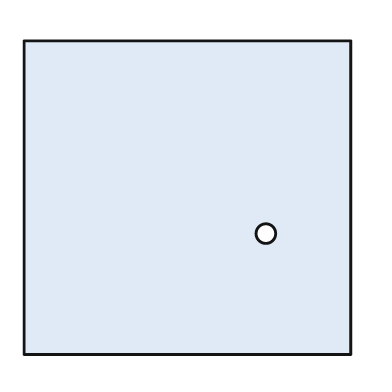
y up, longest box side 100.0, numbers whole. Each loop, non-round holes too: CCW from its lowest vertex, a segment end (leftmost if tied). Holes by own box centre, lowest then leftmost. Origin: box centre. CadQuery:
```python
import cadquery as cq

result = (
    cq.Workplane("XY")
    .moveTo(-50.0, -48.0)
    .lineTo(50.0, -48.0)
    .lineTo(50.0, 48.0)
    .lineTo(-50.0, 48.0)
    .close()
    .moveTo(24.0, -11.0)
    .circle(3.0)
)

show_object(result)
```